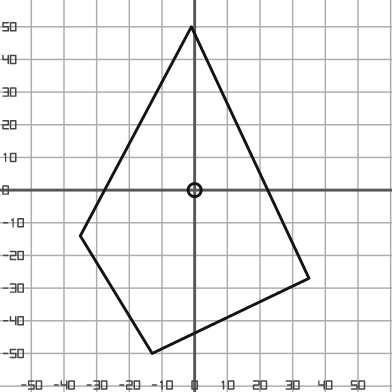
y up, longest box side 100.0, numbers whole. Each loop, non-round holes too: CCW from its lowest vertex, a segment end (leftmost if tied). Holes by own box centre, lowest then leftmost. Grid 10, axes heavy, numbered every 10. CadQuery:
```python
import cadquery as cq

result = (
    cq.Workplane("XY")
    .moveTo(-13.0, -50.0)
    .lineTo(35.0, -27.0)
    .lineTo(-1.0, 50.0)
    .lineTo(-35.0, -14.0)
    .close()
    .moveTo(0.0, 0.0)
    .circle(2.0)
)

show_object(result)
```